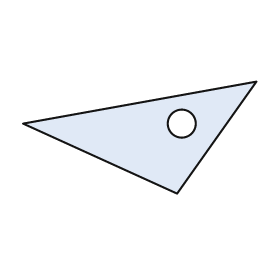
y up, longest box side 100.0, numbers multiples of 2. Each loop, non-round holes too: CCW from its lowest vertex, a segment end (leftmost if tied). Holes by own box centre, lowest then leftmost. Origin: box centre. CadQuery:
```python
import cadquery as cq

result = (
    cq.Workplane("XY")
    .moveTo(16.0, -24.0)
    .lineTo(50.0, 24.0)
    .lineTo(-50.0, 6.0)
    .close()
    .moveTo(18.0, 6.0)
    .circle(6.0)
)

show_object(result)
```